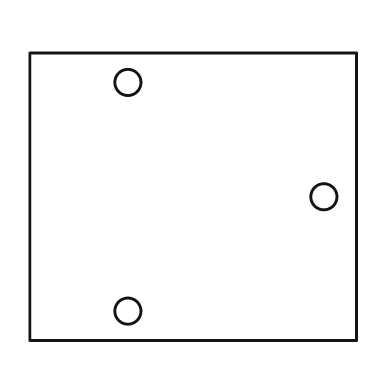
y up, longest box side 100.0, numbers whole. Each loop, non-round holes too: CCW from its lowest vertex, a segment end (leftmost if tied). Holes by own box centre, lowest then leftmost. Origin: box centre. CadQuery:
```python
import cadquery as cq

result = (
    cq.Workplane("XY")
    .moveTo(-50.0, -44.0)
    .lineTo(50.0, -44.0)
    .lineTo(50.0, 44.0)
    .lineTo(-50.0, 44.0)
    .close()
    .moveTo(-20.0, -35.0)
    .circle(4.0)
    .moveTo(40.0, 0.0)
    .circle(4.0)
    .moveTo(-20.0, 35.0)
    .circle(4.0)
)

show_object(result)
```